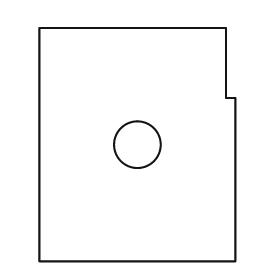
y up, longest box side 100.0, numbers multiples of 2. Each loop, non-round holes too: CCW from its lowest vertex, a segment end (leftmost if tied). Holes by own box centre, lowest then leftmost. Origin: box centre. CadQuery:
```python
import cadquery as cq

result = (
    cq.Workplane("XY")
    .moveTo(-42.0, -50.0)
    .lineTo(42.0, -50.0)
    .lineTo(42.0, 20.0)
    .lineTo(38.0, 20.0)
    .lineTo(38.0, 50.0)
    .lineTo(-42.0, 50.0)
    .close()
    .moveTo(0.0, 0.0)
    .circle(10.0)
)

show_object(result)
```